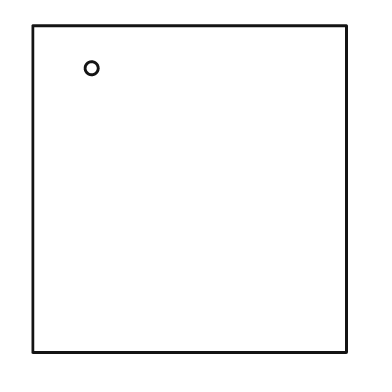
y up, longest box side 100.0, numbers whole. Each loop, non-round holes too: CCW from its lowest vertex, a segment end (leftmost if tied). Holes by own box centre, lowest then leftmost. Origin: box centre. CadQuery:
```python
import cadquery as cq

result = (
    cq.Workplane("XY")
    .moveTo(-48.0, -50.0)
    .lineTo(48.0, -50.0)
    .lineTo(48.0, 50.0)
    .lineTo(-48.0, 50.0)
    .close()
    .moveTo(-30.0, 37.0)
    .circle(2.0)
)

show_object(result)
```